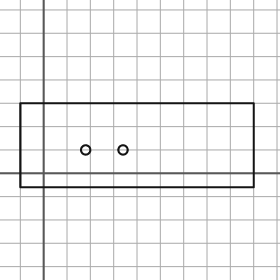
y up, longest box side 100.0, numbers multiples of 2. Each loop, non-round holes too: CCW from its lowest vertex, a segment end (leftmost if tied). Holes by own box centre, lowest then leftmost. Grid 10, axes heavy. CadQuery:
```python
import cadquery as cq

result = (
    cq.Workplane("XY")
    .moveTo(-10.0, -6.0)
    .lineTo(90.0, -6.0)
    .lineTo(90.0, 30.0)
    .lineTo(-10.0, 30.0)
    .close()
    .moveTo(18.0, 10.0)
    .circle(2.0)
    .moveTo(34.0, 10.0)
    .circle(2.0)
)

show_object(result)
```